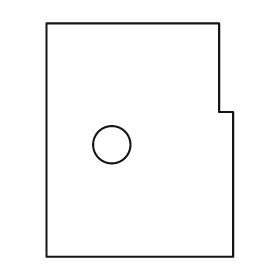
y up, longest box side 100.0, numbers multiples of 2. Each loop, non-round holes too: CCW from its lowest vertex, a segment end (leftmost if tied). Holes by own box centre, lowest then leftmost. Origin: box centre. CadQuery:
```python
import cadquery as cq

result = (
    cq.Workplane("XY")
    .moveTo(-40.0, -50.0)
    .lineTo(40.0, -50.0)
    .lineTo(40.0, 12.0)
    .lineTo(34.0, 12.0)
    .lineTo(34.0, 50.0)
    .lineTo(-40.0, 50.0)
    .close()
    .moveTo(-12.0, -2.0)
    .circle(8.0)
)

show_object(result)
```